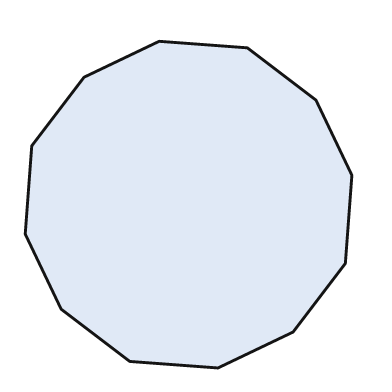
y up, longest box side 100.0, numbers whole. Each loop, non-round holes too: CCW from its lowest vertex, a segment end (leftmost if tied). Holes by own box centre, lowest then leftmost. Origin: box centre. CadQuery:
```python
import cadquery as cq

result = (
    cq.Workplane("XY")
    .moveTo(9.0, -50.0)
    .lineTo(32.0, -39.0)
    .lineTo(48.0, -18.0)
    .lineTo(50.0, 9.0)
    .lineTo(39.0, 32.0)
    .lineTo(18.0, 48.0)
    .lineTo(-9.0, 50.0)
    .lineTo(-32.0, 39.0)
    .lineTo(-48.0, 18.0)
    .lineTo(-50.0, -9.0)
    .lineTo(-39.0, -32.0)
    .lineTo(-18.0, -48.0)
    .close()
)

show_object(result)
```